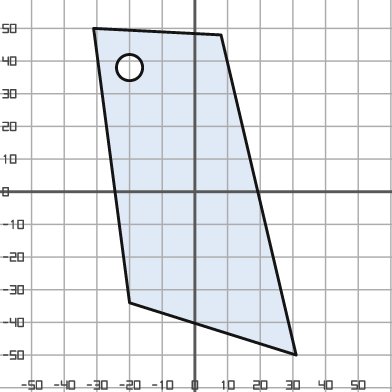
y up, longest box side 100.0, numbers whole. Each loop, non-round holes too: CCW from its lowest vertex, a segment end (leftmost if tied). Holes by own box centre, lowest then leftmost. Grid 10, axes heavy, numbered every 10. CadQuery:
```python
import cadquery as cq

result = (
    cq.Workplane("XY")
    .moveTo(31.0, -50.0)
    .lineTo(8.0, 48.0)
    .lineTo(-31.0, 50.0)
    .lineTo(-20.0, -34.0)
    .close()
    .moveTo(-20.0, 38.0)
    .circle(4.0)
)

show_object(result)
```